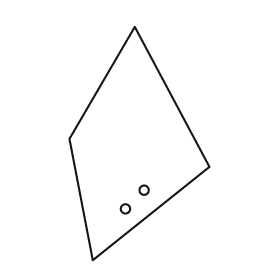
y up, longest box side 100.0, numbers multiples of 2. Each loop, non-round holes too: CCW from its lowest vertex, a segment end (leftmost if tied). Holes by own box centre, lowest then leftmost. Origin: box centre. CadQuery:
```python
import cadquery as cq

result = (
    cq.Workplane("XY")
    .moveTo(-20.0, -50.0)
    .lineTo(30.0, -10.0)
    .lineTo(-2.0, 50.0)
    .lineTo(-30.0, 2.0)
    .close()
    .moveTo(-6.0, -28.0)
    .circle(2.0)
    .moveTo(2.0, -20.0)
    .circle(2.0)
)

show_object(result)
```